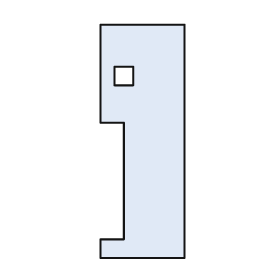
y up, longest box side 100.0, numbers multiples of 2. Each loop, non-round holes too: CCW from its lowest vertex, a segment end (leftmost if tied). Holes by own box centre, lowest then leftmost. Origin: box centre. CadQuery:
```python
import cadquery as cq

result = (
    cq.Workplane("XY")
    .moveTo(-18.0, -50.0)
    .lineTo(18.0, -50.0)
    .lineTo(18.0, 50.0)
    .lineTo(-18.0, 50.0)
    .lineTo(-18.0, 8.0)
    .lineTo(-8.0, 8.0)
    .lineTo(-8.0, -42.0)
    .lineTo(-18.0, -42.0)
    .close()
    .moveTo(-12.0, 24.0)
    .lineTo(-4.0, 24.0)
    .lineTo(-4.0, 32.0)
    .lineTo(-12.0, 32.0)
    .close()
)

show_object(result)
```